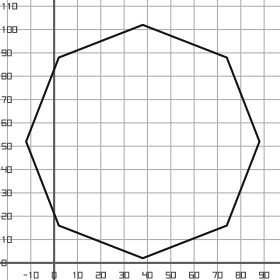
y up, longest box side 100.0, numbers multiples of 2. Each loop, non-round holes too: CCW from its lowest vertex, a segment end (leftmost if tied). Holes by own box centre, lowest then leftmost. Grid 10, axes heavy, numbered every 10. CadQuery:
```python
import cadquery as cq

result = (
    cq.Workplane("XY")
    .moveTo(38.0, 2.0)
    .lineTo(74.0, 16.0)
    .lineTo(88.0, 52.0)
    .lineTo(74.0, 88.0)
    .lineTo(38.0, 102.0)
    .lineTo(2.0, 88.0)
    .lineTo(-12.0, 52.0)
    .lineTo(2.0, 16.0)
    .close()
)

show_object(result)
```